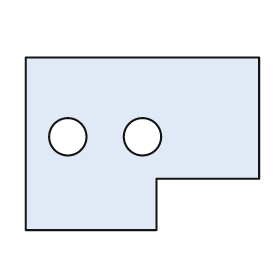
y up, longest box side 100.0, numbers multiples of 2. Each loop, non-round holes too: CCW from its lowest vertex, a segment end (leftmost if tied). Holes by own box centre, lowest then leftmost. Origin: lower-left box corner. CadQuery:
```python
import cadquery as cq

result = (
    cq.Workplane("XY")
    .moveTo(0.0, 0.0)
    .lineTo(56.0, 0.0)
    .lineTo(56.0, 22.0)
    .lineTo(100.0, 22.0)
    .lineTo(100.0, 74.0)
    .lineTo(0.0, 74.0)
    .close()
    .moveTo(18.0, 40.0)
    .circle(8.0)
    .moveTo(50.0, 40.0)
    .circle(8.0)
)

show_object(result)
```